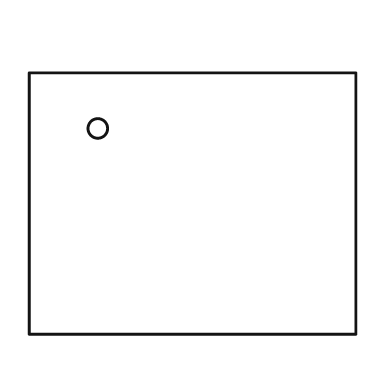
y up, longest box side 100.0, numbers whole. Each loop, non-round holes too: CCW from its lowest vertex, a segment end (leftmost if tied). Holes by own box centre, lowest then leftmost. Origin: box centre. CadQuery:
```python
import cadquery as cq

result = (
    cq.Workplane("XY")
    .moveTo(-50.0, -40.0)
    .lineTo(50.0, -40.0)
    .lineTo(50.0, 40.0)
    .lineTo(-50.0, 40.0)
    .close()
    .moveTo(-29.0, 23.0)
    .circle(3.0)
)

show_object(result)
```